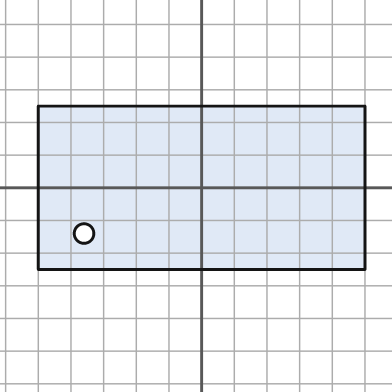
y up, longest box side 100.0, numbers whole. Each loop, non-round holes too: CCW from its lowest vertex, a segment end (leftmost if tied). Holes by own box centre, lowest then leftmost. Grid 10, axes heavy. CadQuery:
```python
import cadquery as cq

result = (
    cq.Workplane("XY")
    .moveTo(-50.0, -25.0)
    .lineTo(50.0, -25.0)
    .lineTo(50.0, 25.0)
    .lineTo(-50.0, 25.0)
    .close()
    .moveTo(-36.0, -14.0)
    .circle(3.0)
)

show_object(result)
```